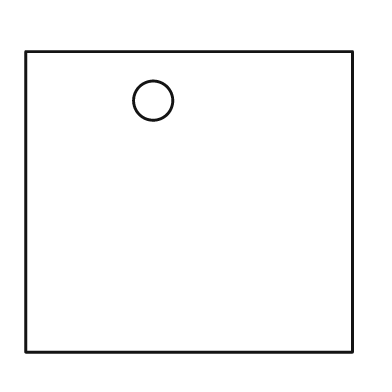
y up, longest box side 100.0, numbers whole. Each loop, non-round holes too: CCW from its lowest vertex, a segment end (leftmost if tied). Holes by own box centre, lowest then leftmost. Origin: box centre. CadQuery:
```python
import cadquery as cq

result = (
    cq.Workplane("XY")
    .moveTo(-50.0, -46.0)
    .lineTo(50.0, -46.0)
    .lineTo(50.0, 46.0)
    .lineTo(-50.0, 46.0)
    .close()
    .moveTo(-11.0, 31.0)
    .circle(6.0)
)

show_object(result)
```